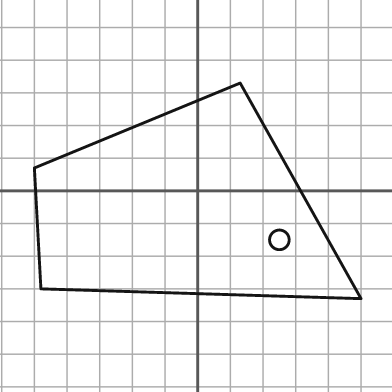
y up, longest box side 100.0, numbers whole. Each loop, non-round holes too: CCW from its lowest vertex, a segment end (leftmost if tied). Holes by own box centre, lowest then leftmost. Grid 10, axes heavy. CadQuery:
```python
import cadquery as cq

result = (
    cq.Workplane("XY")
    .moveTo(50.0, -33.0)
    .lineTo(13.0, 33.0)
    .lineTo(-50.0, 7.0)
    .lineTo(-48.0, -30.0)
    .close()
    .moveTo(25.0, -15.0)
    .circle(3.0)
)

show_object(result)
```